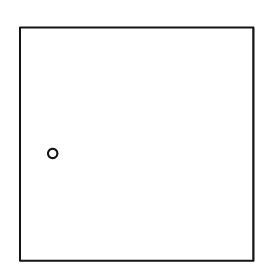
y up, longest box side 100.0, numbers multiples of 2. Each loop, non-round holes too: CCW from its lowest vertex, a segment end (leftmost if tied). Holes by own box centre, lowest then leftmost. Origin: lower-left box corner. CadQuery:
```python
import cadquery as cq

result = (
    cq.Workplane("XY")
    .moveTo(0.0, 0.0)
    .lineTo(100.0, 0.0)
    .lineTo(100.0, 100.0)
    .lineTo(0.0, 100.0)
    .close()
    .moveTo(14.0, 46.0)
    .circle(2.0)
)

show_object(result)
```